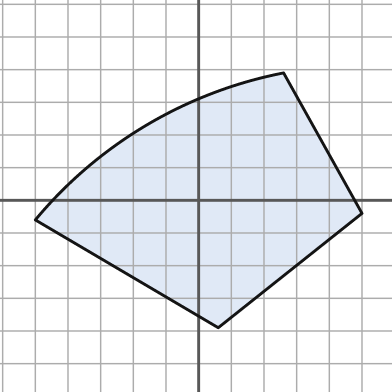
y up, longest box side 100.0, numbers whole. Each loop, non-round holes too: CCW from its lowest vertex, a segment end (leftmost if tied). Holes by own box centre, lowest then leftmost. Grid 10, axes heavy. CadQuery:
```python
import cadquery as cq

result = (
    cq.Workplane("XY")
    .moveTo(6.0, -39.0)
    .lineTo(50.0, -4.0)
    .lineTo(26.0, 39.0)
    .threePointArc((-16.0, 23.0), (-50.0, -6.0))
    .close()
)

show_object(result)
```